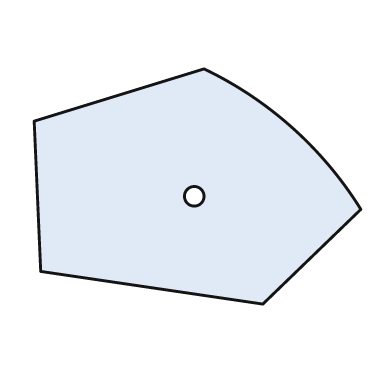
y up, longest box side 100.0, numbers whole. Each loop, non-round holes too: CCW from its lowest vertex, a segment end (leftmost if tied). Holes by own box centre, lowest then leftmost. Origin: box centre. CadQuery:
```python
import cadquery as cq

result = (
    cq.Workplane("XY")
    .moveTo(20.0, -36.0)
    .lineTo(50.0, -7.0)
    .threePointArc((29.0, 18.0), (2.0, 36.0))
    .lineTo(-50.0, 20.0)
    .lineTo(-48.0, -26.0)
    .close()
    .moveTo(-1.0, -3.0)
    .circle(3.0)
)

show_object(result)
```